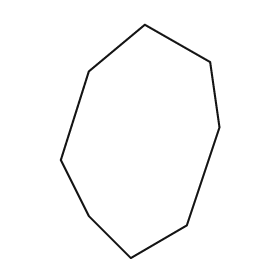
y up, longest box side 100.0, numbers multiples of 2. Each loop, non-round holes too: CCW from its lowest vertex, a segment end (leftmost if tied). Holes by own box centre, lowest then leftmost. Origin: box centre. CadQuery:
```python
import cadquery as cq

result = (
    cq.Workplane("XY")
    .moveTo(-4.0, -50.0)
    .lineTo(20.0, -36.0)
    .lineTo(34.0, 6.0)
    .lineTo(30.0, 34.0)
    .lineTo(2.0, 50.0)
    .lineTo(-22.0, 30.0)
    .lineTo(-34.0, -8.0)
    .lineTo(-22.0, -32.0)
    .close()
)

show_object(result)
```